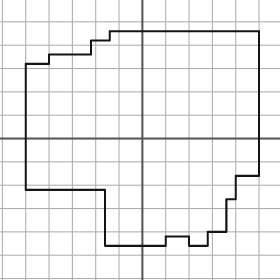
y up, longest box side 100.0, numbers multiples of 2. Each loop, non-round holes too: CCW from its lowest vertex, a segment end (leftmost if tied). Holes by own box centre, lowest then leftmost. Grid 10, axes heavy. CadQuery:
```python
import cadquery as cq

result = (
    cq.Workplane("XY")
    .moveTo(-16.0, -46.0)
    .lineTo(10.0, -46.0)
    .lineTo(10.0, -42.0)
    .lineTo(20.0, -42.0)
    .lineTo(20.0, -46.0)
    .lineTo(28.0, -46.0)
    .lineTo(28.0, -40.0)
    .lineTo(36.0, -40.0)
    .lineTo(36.0, -26.0)
    .lineTo(40.0, -26.0)
    .lineTo(40.0, -16.0)
    .lineTo(50.0, -16.0)
    .lineTo(50.0, 46.0)
    .lineTo(-14.0, 46.0)
    .lineTo(-14.0, 42.0)
    .lineTo(-22.0, 42.0)
    .lineTo(-22.0, 36.0)
    .lineTo(-40.0, 36.0)
    .lineTo(-40.0, 32.0)
    .lineTo(-50.0, 32.0)
    .lineTo(-50.0, -22.0)
    .lineTo(-16.0, -22.0)
    .close()
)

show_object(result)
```